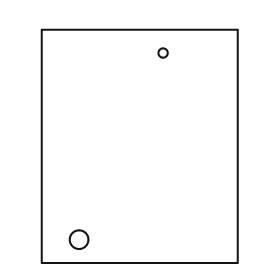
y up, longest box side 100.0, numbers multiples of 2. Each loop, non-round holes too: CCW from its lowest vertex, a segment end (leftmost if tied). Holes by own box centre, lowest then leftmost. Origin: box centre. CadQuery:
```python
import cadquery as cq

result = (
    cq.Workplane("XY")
    .moveTo(-42.0, -50.0)
    .lineTo(42.0, -50.0)
    .lineTo(42.0, 50.0)
    .lineTo(-42.0, 50.0)
    .close()
    .moveTo(-26.0, -40.0)
    .circle(4.0)
    .moveTo(10.0, 40.0)
    .circle(2.0)
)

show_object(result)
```